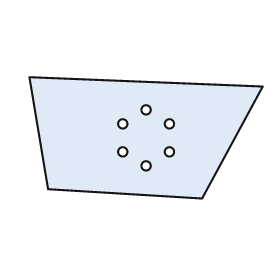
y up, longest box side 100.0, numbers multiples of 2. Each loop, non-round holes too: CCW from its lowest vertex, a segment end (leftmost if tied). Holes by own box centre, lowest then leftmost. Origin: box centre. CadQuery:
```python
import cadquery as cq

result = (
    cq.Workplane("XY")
    .moveTo(24.0, -26.0)
    .lineTo(50.0, 22.0)
    .lineTo(-50.0, 26.0)
    .lineTo(-42.0, -22.0)
    .close()
    .moveTo(0.0, -12.0)
    .circle(2.0)
    .moveTo(-10.0, -6.0)
    .circle(2.0)
    .moveTo(10.0, -6.0)
    .circle(2.0)
    .moveTo(-10.0, 6.0)
    .circle(2.0)
    .moveTo(10.0, 6.0)
    .circle(2.0)
    .moveTo(0.0, 12.0)
    .circle(2.0)
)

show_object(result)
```